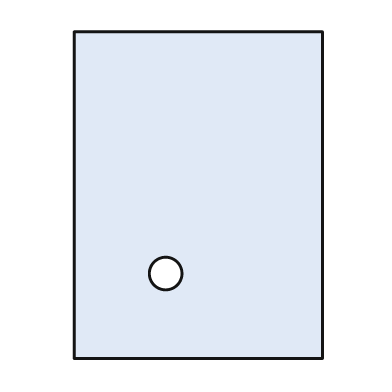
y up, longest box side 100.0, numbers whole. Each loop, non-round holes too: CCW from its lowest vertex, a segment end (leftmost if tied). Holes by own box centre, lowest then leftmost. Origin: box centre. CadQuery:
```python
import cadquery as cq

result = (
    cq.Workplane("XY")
    .moveTo(-38.0, -50.0)
    .lineTo(38.0, -50.0)
    .lineTo(38.0, 50.0)
    .lineTo(-38.0, 50.0)
    .close()
    .moveTo(-10.0, -24.0)
    .circle(5.0)
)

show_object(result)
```